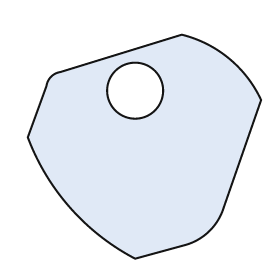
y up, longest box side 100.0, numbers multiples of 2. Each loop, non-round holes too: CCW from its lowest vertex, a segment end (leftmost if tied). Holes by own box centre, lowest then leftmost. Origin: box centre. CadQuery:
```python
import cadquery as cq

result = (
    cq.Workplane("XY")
    .moveTo(-4.0, -48.0)
    .lineTo(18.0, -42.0)
    .threePointArc((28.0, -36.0), (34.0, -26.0))
    .lineTo(50.0, 20.0)
    .threePointArc((36.0, 38.0), (16.0, 48.0))
    .lineTo(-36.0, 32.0)
    .threePointArc((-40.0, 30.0), (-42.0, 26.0))
    .lineTo(-50.0, 4.0)
    .threePointArc((-32.0, -26.0), (-4.0, -48.0))
    .close()
    .moveTo(-4.0, 24.0)
    .circle(12.0)
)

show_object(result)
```